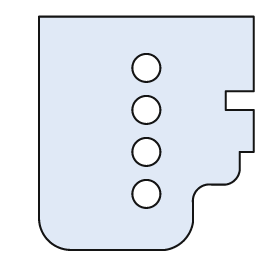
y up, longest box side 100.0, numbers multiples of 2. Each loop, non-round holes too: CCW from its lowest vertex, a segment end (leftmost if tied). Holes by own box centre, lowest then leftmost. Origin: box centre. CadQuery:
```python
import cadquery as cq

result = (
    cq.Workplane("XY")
    .moveTo(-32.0, -50.0)
    .lineTo(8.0, -50.0)
    .threePointArc((16.0, -46.0), (20.0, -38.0))
    .lineTo(20.0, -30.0)
    .threePointArc((22.0, -24.0), (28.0, -22.0))
    .lineTo(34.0, -22.0)
    .threePointArc((38.0, -20.0), (40.0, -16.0))
    .lineTo(40.0, -8.0)
    .lineTo(46.0, -8.0)
    .lineTo(46.0, 10.0)
    .lineTo(34.0, 10.0)
    .lineTo(34.0, 18.0)
    .lineTo(46.0, 18.0)
    .lineTo(46.0, 50.0)
    .lineTo(-46.0, 50.0)
    .lineTo(-46.0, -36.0)
    .threePointArc((-42.0, -46.0), (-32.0, -50.0))
    .close()
    .moveTo(0.0, -26.0)
    .circle(6.0)
    .moveTo(0.0, -8.0)
    .circle(6.0)
    .moveTo(0.0, 10.0)
    .circle(6.0)
    .moveTo(0.0, 28.0)
    .circle(6.0)
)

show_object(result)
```